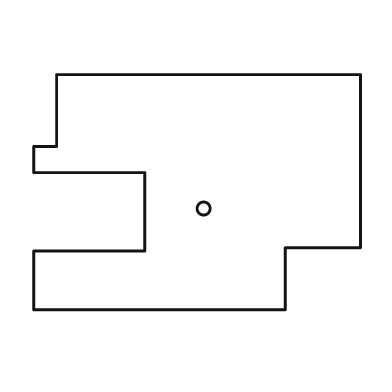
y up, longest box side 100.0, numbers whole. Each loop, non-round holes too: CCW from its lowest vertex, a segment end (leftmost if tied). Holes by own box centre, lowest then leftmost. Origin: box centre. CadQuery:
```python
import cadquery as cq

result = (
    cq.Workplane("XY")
    .moveTo(-50.0, -36.0)
    .lineTo(27.0, -36.0)
    .lineTo(27.0, -17.0)
    .lineTo(50.0, -17.0)
    .lineTo(50.0, 36.0)
    .lineTo(-43.0, 36.0)
    .lineTo(-43.0, 14.0)
    .lineTo(-50.0, 14.0)
    .lineTo(-50.0, 6.0)
    .lineTo(-16.0, 6.0)
    .lineTo(-16.0, -18.0)
    .lineTo(-50.0, -18.0)
    .close()
    .moveTo(2.0, -5.0)
    .circle(2.0)
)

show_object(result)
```